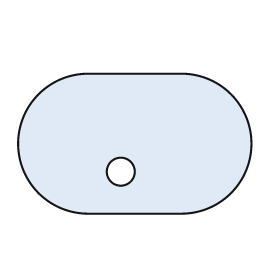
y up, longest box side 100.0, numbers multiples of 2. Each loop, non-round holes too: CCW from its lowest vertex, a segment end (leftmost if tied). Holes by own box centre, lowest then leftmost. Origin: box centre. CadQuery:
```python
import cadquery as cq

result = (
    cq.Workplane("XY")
    .moveTo(-20.0, -30.0)
    .lineTo(20.0, -30.0)
    .threePointArc((50.0, 0.0), (20.0, 30.0))
    .lineTo(-20.0, 30.0)
    .threePointArc((-50.0, 0.0), (-20.0, -30.0))
    .close()
    .moveTo(-6.0, -12.0)
    .circle(6.0)
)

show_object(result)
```